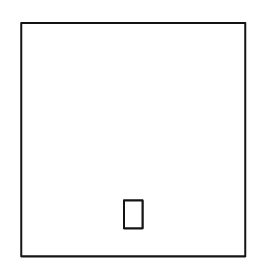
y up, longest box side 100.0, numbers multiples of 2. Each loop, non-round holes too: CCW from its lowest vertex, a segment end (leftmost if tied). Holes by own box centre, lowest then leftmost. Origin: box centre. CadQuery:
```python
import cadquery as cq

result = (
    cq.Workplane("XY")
    .moveTo(-48.0, -50.0)
    .lineTo(48.0, -50.0)
    .lineTo(48.0, 50.0)
    .lineTo(-48.0, 50.0)
    .close()
    .moveTo(-4.0, -38.0)
    .lineTo(4.0, -38.0)
    .lineTo(4.0, -26.0)
    .lineTo(-4.0, -26.0)
    .close()
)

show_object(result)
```